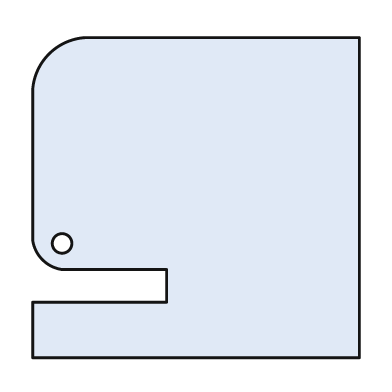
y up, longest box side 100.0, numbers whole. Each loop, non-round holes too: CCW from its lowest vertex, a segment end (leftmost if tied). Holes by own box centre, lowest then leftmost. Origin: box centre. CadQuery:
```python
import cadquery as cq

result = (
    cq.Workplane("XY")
    .moveTo(-50.0, -49.0)
    .lineTo(50.0, -49.0)
    .lineTo(50.0, 49.0)
    .lineTo(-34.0, 49.0)
    .threePointArc((-45.0, 44.0), (-50.0, 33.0))
    .lineTo(-50.0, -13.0)
    .threePointArc((-47.0, -19.0), (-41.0, -22.0))
    .lineTo(-9.0, -22.0)
    .lineTo(-9.0, -32.0)
    .lineTo(-50.0, -32.0)
    .close()
    .moveTo(-41.0, -14.0)
    .circle(3.0)
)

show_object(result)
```